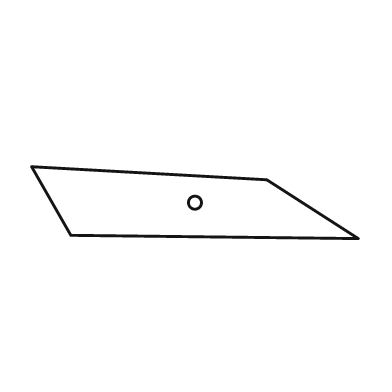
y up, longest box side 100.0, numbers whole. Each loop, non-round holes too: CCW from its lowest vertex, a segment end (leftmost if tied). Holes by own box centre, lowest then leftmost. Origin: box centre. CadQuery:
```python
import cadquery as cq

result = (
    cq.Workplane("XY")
    .moveTo(50.0, -11.0)
    .lineTo(22.0, 7.0)
    .lineTo(-50.0, 11.0)
    .lineTo(-38.0, -10.0)
    .close()
    .moveTo(0.0, 0.0)
    .circle(2.0)
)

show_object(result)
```